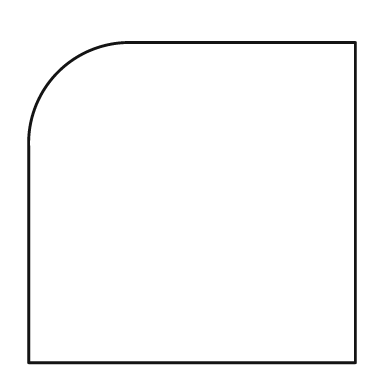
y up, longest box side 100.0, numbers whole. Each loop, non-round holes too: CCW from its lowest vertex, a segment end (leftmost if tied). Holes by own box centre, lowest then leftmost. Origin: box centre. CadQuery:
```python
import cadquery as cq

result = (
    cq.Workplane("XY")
    .moveTo(-50.0, -49.0)
    .lineTo(50.0, -49.0)
    .lineTo(50.0, 49.0)
    .lineTo(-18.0, 49.0)
    .threePointArc((-41.0, 40.0), (-50.0, 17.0))
    .close()
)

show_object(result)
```